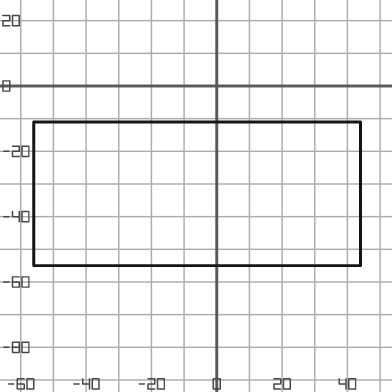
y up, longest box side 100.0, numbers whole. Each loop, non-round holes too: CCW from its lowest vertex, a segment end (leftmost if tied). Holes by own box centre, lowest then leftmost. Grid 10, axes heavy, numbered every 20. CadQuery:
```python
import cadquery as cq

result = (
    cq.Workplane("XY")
    .moveTo(-56.0, -55.0)
    .lineTo(44.0, -55.0)
    .lineTo(44.0, -11.0)
    .lineTo(-56.0, -11.0)
    .close()
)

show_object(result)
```